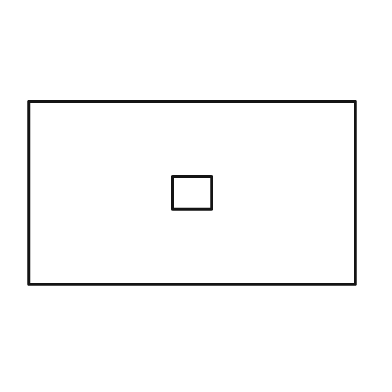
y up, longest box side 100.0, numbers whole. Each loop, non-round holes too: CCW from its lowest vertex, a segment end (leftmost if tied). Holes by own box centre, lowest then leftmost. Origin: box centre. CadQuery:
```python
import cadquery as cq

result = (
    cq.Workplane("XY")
    .moveTo(-50.0, -28.0)
    .lineTo(50.0, -28.0)
    .lineTo(50.0, 28.0)
    .lineTo(-50.0, 28.0)
    .close()
    .moveTo(-6.0, -5.0)
    .lineTo(6.0, -5.0)
    .lineTo(6.0, 5.0)
    .lineTo(-6.0, 5.0)
    .close()
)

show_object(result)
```